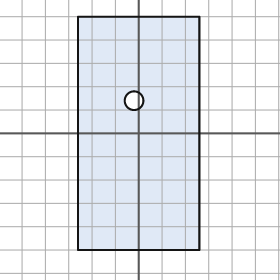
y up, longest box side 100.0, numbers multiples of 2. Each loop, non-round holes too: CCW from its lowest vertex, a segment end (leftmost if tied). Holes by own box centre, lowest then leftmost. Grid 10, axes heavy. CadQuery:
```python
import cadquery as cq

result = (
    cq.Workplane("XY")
    .moveTo(-26.0, -50.0)
    .lineTo(26.0, -50.0)
    .lineTo(26.0, 50.0)
    .lineTo(-26.0, 50.0)
    .close()
    .moveTo(-2.0, 14.0)
    .circle(4.0)
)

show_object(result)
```